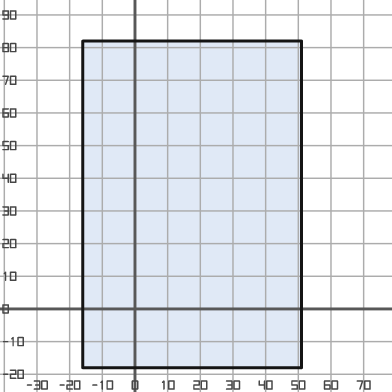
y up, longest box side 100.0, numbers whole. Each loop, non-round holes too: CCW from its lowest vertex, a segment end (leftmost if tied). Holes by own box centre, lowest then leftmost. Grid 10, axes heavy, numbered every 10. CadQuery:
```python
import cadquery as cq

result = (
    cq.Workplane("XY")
    .moveTo(-16.0, -18.0)
    .lineTo(51.0, -18.0)
    .lineTo(51.0, 82.0)
    .lineTo(-16.0, 82.0)
    .close()
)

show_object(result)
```